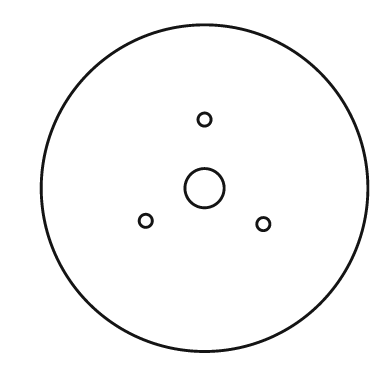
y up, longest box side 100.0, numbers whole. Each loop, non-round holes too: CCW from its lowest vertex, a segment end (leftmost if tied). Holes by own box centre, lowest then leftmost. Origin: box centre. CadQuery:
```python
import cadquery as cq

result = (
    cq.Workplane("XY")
    .moveTo(0.0, 0.0)
    .circle(50.0)
    .moveTo(18.0, -11.0)
    .circle(2.0)
    .moveTo(-18.0, -10.0)
    .circle(2.0)
    .moveTo(0.0, 0.0)
    .circle(6.0)
    .moveTo(0.0, 21.0)
    .circle(2.0)
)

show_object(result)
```